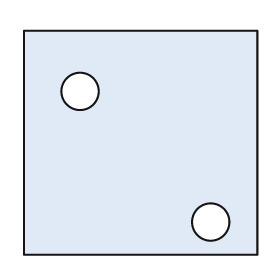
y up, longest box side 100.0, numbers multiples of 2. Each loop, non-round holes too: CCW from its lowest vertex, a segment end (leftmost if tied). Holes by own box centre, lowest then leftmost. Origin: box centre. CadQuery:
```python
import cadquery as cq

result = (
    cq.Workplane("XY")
    .moveTo(-50.0, -48.0)
    .lineTo(50.0, -48.0)
    .lineTo(50.0, 48.0)
    .lineTo(-50.0, 48.0)
    .close()
    .moveTo(30.0, -34.0)
    .circle(8.0)
    .moveTo(-26.0, 22.0)
    .circle(8.0)
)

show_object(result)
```